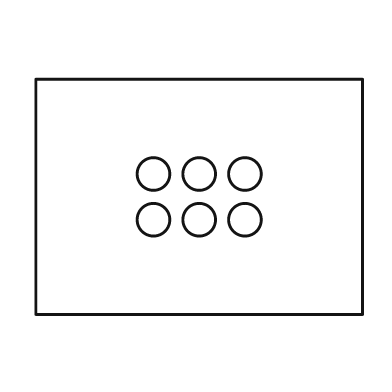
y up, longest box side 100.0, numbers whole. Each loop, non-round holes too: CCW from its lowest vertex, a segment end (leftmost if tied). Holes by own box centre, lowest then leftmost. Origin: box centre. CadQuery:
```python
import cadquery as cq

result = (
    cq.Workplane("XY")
    .moveTo(-50.0, -36.0)
    .lineTo(50.0, -36.0)
    .lineTo(50.0, 36.0)
    .lineTo(-50.0, 36.0)
    .close()
    .moveTo(-14.0, -7.0)
    .circle(5.0)
    .moveTo(0.0, -7.0)
    .circle(5.0)
    .moveTo(14.0, -7.0)
    .circle(5.0)
    .moveTo(-14.0, 7.0)
    .circle(5.0)
    .moveTo(0.0, 7.0)
    .circle(5.0)
    .moveTo(14.0, 7.0)
    .circle(5.0)
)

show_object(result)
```